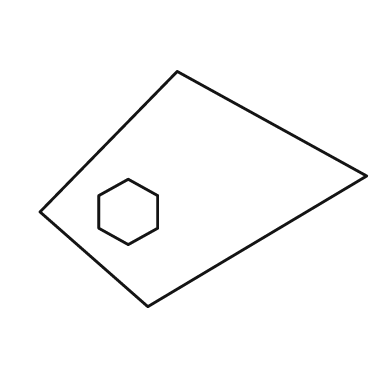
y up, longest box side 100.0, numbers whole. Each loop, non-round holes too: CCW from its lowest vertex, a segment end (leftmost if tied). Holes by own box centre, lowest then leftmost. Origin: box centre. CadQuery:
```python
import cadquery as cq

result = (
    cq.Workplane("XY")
    .moveTo(-17.0, -36.0)
    .lineTo(50.0, 4.0)
    .lineTo(-8.0, 36.0)
    .lineTo(-50.0, -7.0)
    .close()
    .moveTo(-23.0, -17.0)
    .lineTo(-14.0, -12.0)
    .lineTo(-14.0, -2.0)
    .lineTo(-23.0, 3.0)
    .lineTo(-32.0, -2.0)
    .lineTo(-32.0, -12.0)
    .close()
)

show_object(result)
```